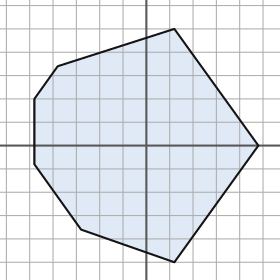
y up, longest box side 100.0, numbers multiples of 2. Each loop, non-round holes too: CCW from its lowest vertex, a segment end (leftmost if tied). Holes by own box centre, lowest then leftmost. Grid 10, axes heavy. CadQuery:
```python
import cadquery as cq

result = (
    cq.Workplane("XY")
    .moveTo(12.0, -50.0)
    .lineTo(48.0, 0.0)
    .lineTo(12.0, 50.0)
    .lineTo(-38.0, 34.0)
    .lineTo(-48.0, 20.0)
    .lineTo(-48.0, -8.0)
    .lineTo(-28.0, -36.0)
    .close()
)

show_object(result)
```